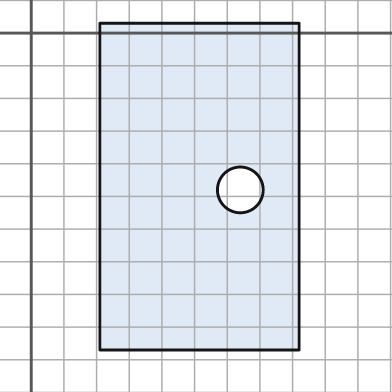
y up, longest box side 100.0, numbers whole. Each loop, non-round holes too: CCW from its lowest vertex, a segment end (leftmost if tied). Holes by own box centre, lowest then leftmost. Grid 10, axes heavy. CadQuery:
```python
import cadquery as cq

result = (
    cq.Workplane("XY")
    .moveTo(21.0, -97.0)
    .lineTo(82.0, -97.0)
    .lineTo(82.0, 3.0)
    .lineTo(21.0, 3.0)
    .close()
    .moveTo(64.0, -48.0)
    .circle(7.0)
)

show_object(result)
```